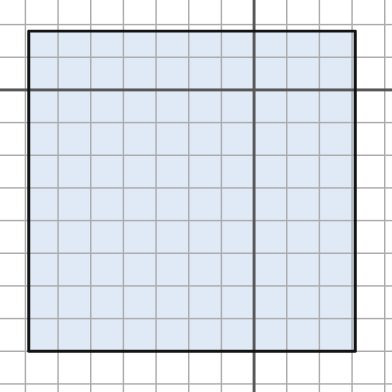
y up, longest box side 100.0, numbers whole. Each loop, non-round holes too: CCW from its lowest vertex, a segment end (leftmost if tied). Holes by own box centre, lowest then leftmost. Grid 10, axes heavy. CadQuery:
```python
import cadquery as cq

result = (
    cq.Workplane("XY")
    .moveTo(-69.0, -80.0)
    .lineTo(31.0, -80.0)
    .lineTo(31.0, 18.0)
    .lineTo(-69.0, 18.0)
    .close()
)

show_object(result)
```